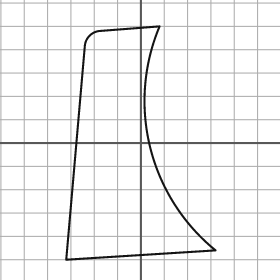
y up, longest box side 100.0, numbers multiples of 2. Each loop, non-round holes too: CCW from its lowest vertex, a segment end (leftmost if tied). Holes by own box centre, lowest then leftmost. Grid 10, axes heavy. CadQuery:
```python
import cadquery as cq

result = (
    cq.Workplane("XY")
    .moveTo(-32.0, -50.0)
    .lineTo(32.0, -46.0)
    .threePointArc((4.0, -2.0), (8.0, 50.0))
    .lineTo(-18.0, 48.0)
    .threePointArc((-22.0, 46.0), (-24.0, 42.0))
    .close()
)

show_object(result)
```